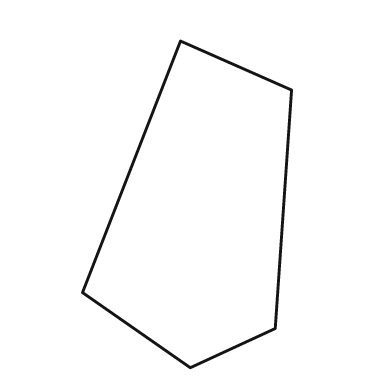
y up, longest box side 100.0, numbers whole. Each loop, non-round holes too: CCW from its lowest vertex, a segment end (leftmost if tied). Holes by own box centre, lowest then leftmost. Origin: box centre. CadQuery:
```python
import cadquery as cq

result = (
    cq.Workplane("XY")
    .moveTo(1.0, -50.0)
    .lineTo(27.0, -38.0)
    .lineTo(32.0, 35.0)
    .lineTo(-2.0, 50.0)
    .lineTo(-32.0, -27.0)
    .close()
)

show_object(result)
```